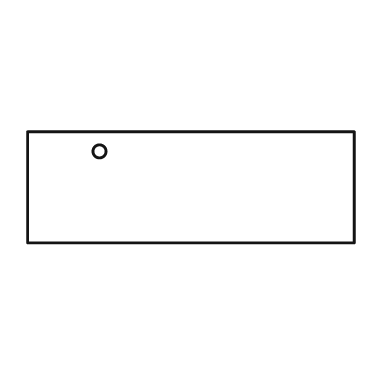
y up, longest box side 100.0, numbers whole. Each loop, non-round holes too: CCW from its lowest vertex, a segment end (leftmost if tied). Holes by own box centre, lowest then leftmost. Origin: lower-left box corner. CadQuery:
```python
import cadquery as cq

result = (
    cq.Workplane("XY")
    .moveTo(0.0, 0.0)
    .lineTo(100.0, 0.0)
    .lineTo(100.0, 34.0)
    .lineTo(0.0, 34.0)
    .close()
    .moveTo(22.0, 28.0)
    .circle(2.0)
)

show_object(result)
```